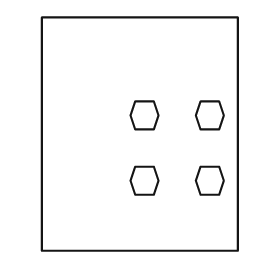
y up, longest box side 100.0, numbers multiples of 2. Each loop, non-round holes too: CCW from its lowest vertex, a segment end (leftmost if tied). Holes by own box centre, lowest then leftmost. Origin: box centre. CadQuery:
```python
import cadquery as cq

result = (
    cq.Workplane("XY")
    .moveTo(-42.0, -50.0)
    .lineTo(42.0, -50.0)
    .lineTo(42.0, 50.0)
    .lineTo(-42.0, 50.0)
    .close()
    .moveTo(-2.0, -26.0)
    .lineTo(6.0, -26.0)
    .lineTo(8.0, -20.0)
    .lineTo(6.0, -14.0)
    .lineTo(-2.0, -14.0)
    .lineTo(-4.0, -20.0)
    .close()
    .moveTo(26.0, -26.0)
    .lineTo(34.0, -26.0)
    .lineTo(36.0, -20.0)
    .lineTo(34.0, -14.0)
    .lineTo(26.0, -14.0)
    .lineTo(24.0, -20.0)
    .close()
    .moveTo(-2.0, 2.0)
    .lineTo(6.0, 2.0)
    .lineTo(8.0, 8.0)
    .lineTo(6.0, 14.0)
    .lineTo(-2.0, 14.0)
    .lineTo(-4.0, 8.0)
    .close()
    .moveTo(26.0, 2.0)
    .lineTo(34.0, 2.0)
    .lineTo(36.0, 8.0)
    .lineTo(34.0, 14.0)
    .lineTo(26.0, 14.0)
    .lineTo(24.0, 8.0)
    .close()
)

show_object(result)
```